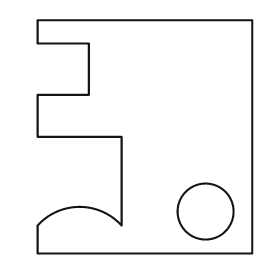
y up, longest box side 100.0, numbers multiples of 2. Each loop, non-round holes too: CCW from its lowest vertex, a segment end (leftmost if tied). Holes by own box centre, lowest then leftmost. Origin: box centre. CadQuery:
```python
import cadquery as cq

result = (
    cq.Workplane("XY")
    .moveTo(-46.0, -50.0)
    .lineTo(46.0, -50.0)
    .lineTo(46.0, 50.0)
    .lineTo(-46.0, 50.0)
    .lineTo(-46.0, 40.0)
    .lineTo(-24.0, 40.0)
    .lineTo(-24.0, 18.0)
    .lineTo(-46.0, 18.0)
    .lineTo(-46.0, 0.0)
    .lineTo(-10.0, 0.0)
    .lineTo(-10.0, -38.0)
    .threePointArc((-28.0, -30.0), (-46.0, -38.0))
    .close()
    .moveTo(26.0, -32.0)
    .circle(12.0)
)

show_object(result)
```